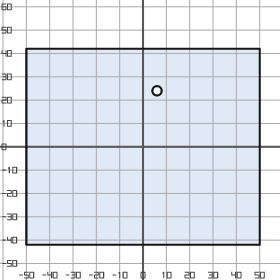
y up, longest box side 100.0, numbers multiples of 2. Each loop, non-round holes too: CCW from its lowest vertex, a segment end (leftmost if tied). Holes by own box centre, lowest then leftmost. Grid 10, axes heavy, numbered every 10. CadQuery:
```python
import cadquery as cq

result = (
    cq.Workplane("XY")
    .moveTo(-50.0, -42.0)
    .lineTo(50.0, -42.0)
    .lineTo(50.0, 42.0)
    .lineTo(-50.0, 42.0)
    .close()
    .moveTo(6.0, 24.0)
    .circle(2.0)
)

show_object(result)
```